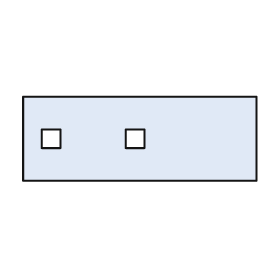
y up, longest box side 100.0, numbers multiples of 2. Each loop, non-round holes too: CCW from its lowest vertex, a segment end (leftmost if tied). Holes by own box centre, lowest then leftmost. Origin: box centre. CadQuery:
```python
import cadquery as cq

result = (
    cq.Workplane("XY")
    .moveTo(-50.0, -18.0)
    .lineTo(50.0, -18.0)
    .lineTo(50.0, 18.0)
    .lineTo(-50.0, 18.0)
    .close()
    .moveTo(-42.0, -4.0)
    .lineTo(-34.0, -4.0)
    .lineTo(-34.0, 4.0)
    .lineTo(-42.0, 4.0)
    .close()
    .moveTo(-6.0, -4.0)
    .lineTo(2.0, -4.0)
    .lineTo(2.0, 4.0)
    .lineTo(-6.0, 4.0)
    .close()
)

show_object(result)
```